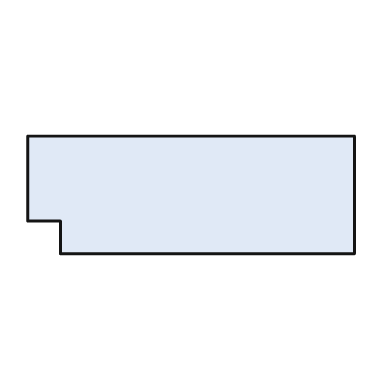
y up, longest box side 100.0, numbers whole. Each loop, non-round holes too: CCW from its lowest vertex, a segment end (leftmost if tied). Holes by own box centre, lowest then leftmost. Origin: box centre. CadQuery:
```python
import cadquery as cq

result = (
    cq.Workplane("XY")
    .moveTo(-40.0, -18.0)
    .lineTo(50.0, -18.0)
    .lineTo(50.0, 18.0)
    .lineTo(-50.0, 18.0)
    .lineTo(-50.0, -8.0)
    .lineTo(-40.0, -8.0)
    .close()
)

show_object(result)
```